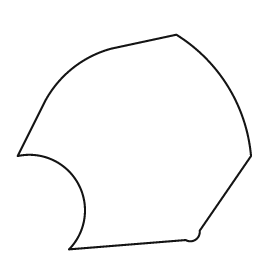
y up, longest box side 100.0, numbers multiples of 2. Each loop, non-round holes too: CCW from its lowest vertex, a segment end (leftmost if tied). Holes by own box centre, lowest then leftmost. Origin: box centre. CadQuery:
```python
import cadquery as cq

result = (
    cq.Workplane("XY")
    .moveTo(-28.0, -46.0)
    .lineTo(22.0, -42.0)
    .threePointArc((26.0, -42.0), (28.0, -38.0))
    .lineTo(50.0, -6.0)
    .threePointArc((40.0, 24.0), (18.0, 46.0))
    .lineTo(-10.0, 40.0)
    .threePointArc((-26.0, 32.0), (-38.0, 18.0))
    .lineTo(-50.0, -6.0)
    .threePointArc((-24.0, -18.0), (-28.0, -46.0))
    .close()
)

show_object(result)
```